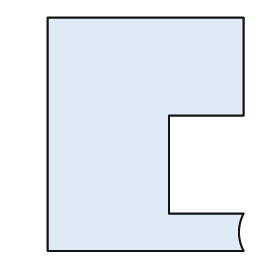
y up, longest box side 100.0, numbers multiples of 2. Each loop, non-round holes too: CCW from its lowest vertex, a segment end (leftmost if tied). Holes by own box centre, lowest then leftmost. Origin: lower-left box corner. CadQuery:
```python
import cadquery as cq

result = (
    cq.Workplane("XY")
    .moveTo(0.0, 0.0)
    .lineTo(84.0, 0.0)
    .threePointArc((82.0, 8.0), (84.0, 16.0))
    .lineTo(52.0, 16.0)
    .lineTo(52.0, 58.0)
    .lineTo(84.0, 58.0)
    .lineTo(84.0, 100.0)
    .lineTo(0.0, 100.0)
    .close()
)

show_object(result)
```